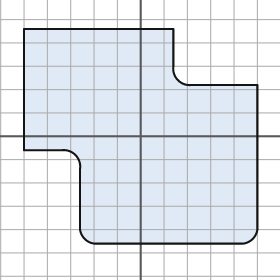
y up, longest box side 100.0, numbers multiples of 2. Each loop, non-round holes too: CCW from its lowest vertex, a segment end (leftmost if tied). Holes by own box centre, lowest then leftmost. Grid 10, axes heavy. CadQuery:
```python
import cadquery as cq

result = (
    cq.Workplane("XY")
    .moveTo(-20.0, -46.0)
    .lineTo(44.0, -46.0)
    .threePointArc((48.0, -44.0), (50.0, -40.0))
    .lineTo(50.0, 22.0)
    .lineTo(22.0, 22.0)
    .threePointArc((16.0, 24.0), (14.0, 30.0))
    .lineTo(14.0, 46.0)
    .lineTo(-50.0, 46.0)
    .lineTo(-50.0, -6.0)
    .lineTo(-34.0, -6.0)
    .threePointArc((-28.0, -8.0), (-26.0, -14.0))
    .lineTo(-26.0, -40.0)
    .threePointArc((-24.0, -44.0), (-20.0, -46.0))
    .close()
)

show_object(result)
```